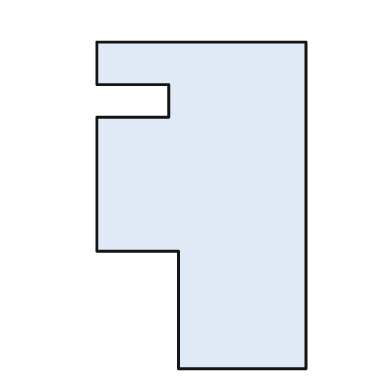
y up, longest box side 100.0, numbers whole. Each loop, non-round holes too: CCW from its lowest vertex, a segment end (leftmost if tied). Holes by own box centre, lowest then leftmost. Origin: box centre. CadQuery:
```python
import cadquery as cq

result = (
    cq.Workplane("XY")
    .moveTo(-7.0, -50.0)
    .lineTo(32.0, -50.0)
    .lineTo(32.0, 50.0)
    .lineTo(-32.0, 50.0)
    .lineTo(-32.0, 37.0)
    .lineTo(-10.0, 37.0)
    .lineTo(-10.0, 27.0)
    .lineTo(-32.0, 27.0)
    .lineTo(-32.0, -14.0)
    .lineTo(-7.0, -14.0)
    .close()
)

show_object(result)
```